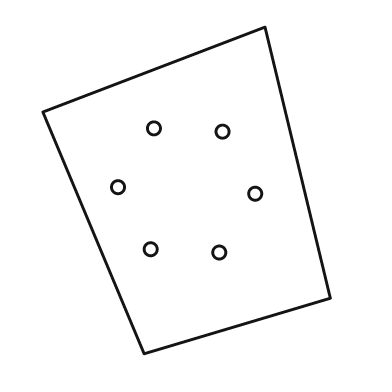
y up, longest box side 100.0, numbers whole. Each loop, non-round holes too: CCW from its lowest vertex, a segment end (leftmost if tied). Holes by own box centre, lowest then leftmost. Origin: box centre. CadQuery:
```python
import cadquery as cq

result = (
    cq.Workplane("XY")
    .moveTo(-13.0, -50.0)
    .lineTo(44.0, -33.0)
    .lineTo(24.0, 50.0)
    .lineTo(-44.0, 24.0)
    .close()
    .moveTo(10.0, -19.0)
    .circle(2.0)
    .moveTo(-11.0, -18.0)
    .circle(2.0)
    .moveTo(21.0, -1.0)
    .circle(2.0)
    .moveTo(-21.0, 1.0)
    .circle(2.0)
    .moveTo(11.0, 18.0)
    .circle(2.0)
    .moveTo(-10.0, 19.0)
    .circle(2.0)
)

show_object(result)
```